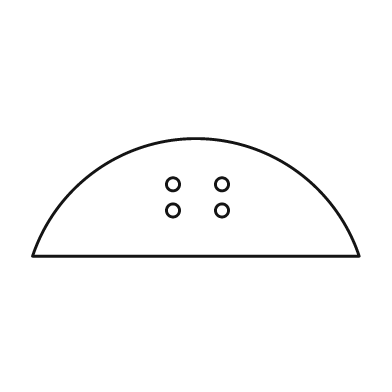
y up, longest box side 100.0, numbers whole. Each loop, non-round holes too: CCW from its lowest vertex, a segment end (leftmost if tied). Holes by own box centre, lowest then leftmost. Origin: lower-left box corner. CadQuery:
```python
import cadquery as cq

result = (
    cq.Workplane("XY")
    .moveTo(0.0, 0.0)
    .lineTo(100.0, 0.0)
    .threePointArc((50.0, 36.0), (0.0, 0.0))
    .close()
    .moveTo(43.0, 14.0)
    .circle(2.0)
    .moveTo(58.0, 14.0)
    .circle(2.0)
    .moveTo(43.0, 22.0)
    .circle(2.0)
    .moveTo(58.0, 22.0)
    .circle(2.0)
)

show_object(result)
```